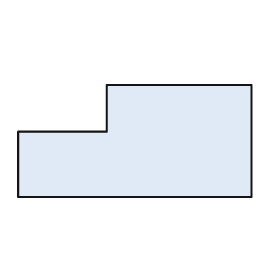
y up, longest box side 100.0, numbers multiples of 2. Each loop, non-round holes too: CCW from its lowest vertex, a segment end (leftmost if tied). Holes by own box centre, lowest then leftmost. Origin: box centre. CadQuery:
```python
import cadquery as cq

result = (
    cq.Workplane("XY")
    .moveTo(-50.0, -24.0)
    .lineTo(50.0, -24.0)
    .lineTo(50.0, 24.0)
    .lineTo(-12.0, 24.0)
    .lineTo(-12.0, 4.0)
    .lineTo(-50.0, 4.0)
    .close()
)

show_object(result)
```